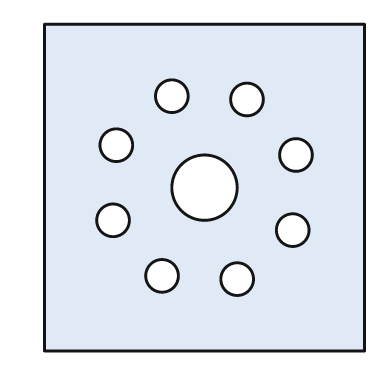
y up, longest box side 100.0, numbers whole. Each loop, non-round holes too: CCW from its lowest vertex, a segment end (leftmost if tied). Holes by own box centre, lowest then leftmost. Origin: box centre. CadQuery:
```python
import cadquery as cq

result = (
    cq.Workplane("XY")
    .moveTo(-49.0, -50.0)
    .lineTo(49.0, -50.0)
    .lineTo(49.0, 50.0)
    .lineTo(-49.0, 50.0)
    .close()
    .moveTo(10.0, -28.0)
    .circle(5.0)
    .moveTo(-13.0, -27.0)
    .circle(5.0)
    .moveTo(27.0, -13.0)
    .circle(5.0)
    .moveTo(-28.0, -10.0)
    .circle(5.0)
    .moveTo(0.0, 0.0)
    .circle(10.0)
    .moveTo(28.0, 10.0)
    .circle(5.0)
    .moveTo(-27.0, 13.0)
    .circle(5.0)
    .moveTo(13.0, 27.0)
    .circle(5.0)
    .moveTo(-10.0, 28.0)
    .circle(5.0)
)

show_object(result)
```